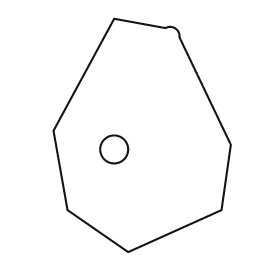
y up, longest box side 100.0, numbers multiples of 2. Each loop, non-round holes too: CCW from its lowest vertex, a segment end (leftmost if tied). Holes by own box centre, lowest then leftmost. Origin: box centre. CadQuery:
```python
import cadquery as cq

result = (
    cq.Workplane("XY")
    .moveTo(-6.0, -50.0)
    .lineTo(34.0, -32.0)
    .lineTo(38.0, -4.0)
    .lineTo(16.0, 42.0)
    .threePointArc((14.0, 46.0), (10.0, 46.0))
    .lineTo(-12.0, 50.0)
    .lineTo(-38.0, 2.0)
    .lineTo(-32.0, -32.0)
    .close()
    .moveTo(-12.0, -6.0)
    .circle(6.0)
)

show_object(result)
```